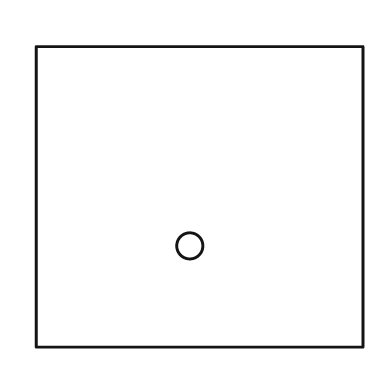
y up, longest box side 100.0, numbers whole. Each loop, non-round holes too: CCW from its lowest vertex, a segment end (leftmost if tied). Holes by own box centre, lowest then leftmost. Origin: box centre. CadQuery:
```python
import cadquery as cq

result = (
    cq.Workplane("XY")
    .moveTo(-50.0, -46.0)
    .lineTo(50.0, -46.0)
    .lineTo(50.0, 46.0)
    .lineTo(-50.0, 46.0)
    .close()
    .moveTo(-3.0, -15.0)
    .circle(4.0)
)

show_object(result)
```